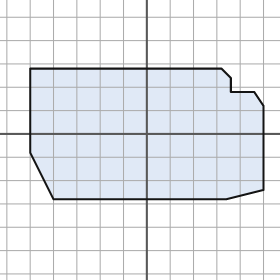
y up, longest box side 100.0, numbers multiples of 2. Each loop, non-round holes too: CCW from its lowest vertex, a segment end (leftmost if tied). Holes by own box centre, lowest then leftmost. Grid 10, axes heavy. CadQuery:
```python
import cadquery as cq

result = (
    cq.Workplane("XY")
    .moveTo(-40.0, -28.0)
    .lineTo(34.0, -28.0)
    .lineTo(50.0, -24.0)
    .lineTo(50.0, 12.0)
    .lineTo(46.0, 18.0)
    .lineTo(36.0, 18.0)
    .lineTo(36.0, 24.0)
    .lineTo(32.0, 28.0)
    .lineTo(-50.0, 28.0)
    .lineTo(-50.0, -8.0)
    .close()
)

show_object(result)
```